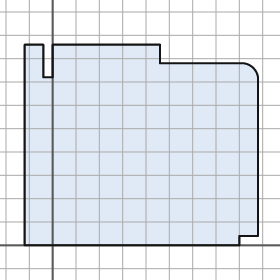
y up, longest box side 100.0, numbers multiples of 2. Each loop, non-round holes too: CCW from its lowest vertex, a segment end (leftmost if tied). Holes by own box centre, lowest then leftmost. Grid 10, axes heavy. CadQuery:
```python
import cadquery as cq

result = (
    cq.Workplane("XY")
    .moveTo(-12.0, 0.0)
    .lineTo(80.0, 0.0)
    .lineTo(80.0, 4.0)
    .lineTo(88.0, 4.0)
    .lineTo(88.0, 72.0)
    .threePointArc((86.0, 76.0), (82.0, 78.0))
    .lineTo(46.0, 78.0)
    .lineTo(46.0, 86.0)
    .lineTo(0.0, 86.0)
    .lineTo(0.0, 72.0)
    .lineTo(-4.0, 72.0)
    .lineTo(-4.0, 86.0)
    .lineTo(-12.0, 86.0)
    .close()
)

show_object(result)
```